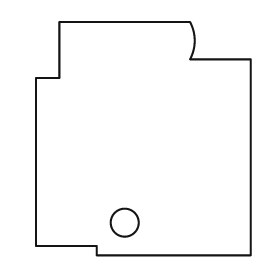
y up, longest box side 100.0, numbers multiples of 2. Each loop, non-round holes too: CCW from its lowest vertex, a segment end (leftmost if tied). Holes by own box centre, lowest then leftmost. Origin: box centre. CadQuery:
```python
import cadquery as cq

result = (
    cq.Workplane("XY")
    .moveTo(-20.0, -50.0)
    .lineTo(46.0, -50.0)
    .lineTo(46.0, 34.0)
    .lineTo(20.0, 34.0)
    .threePointArc((22.0, 42.0), (20.0, 50.0))
    .lineTo(-36.0, 50.0)
    .lineTo(-36.0, 26.0)
    .lineTo(-46.0, 26.0)
    .lineTo(-46.0, -46.0)
    .lineTo(-20.0, -46.0)
    .close()
    .moveTo(-8.0, -36.0)
    .circle(6.0)
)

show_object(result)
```